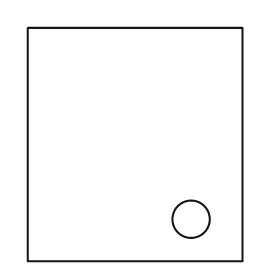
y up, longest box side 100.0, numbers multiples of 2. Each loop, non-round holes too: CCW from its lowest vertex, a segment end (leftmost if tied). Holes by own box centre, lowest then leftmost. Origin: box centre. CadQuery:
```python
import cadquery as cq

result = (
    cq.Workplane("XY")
    .moveTo(-46.0, -50.0)
    .lineTo(46.0, -50.0)
    .lineTo(46.0, 50.0)
    .lineTo(-46.0, 50.0)
    .close()
    .moveTo(24.0, -32.0)
    .circle(8.0)
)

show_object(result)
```